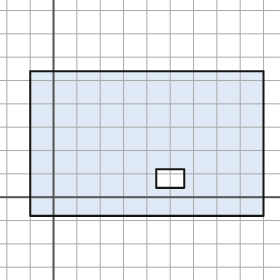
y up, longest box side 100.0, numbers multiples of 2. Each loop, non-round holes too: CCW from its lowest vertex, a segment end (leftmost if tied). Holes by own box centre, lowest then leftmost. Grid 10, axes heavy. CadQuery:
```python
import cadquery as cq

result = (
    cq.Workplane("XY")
    .moveTo(-10.0, -8.0)
    .lineTo(90.0, -8.0)
    .lineTo(90.0, 54.0)
    .lineTo(-10.0, 54.0)
    .close()
    .moveTo(44.0, 4.0)
    .lineTo(56.0, 4.0)
    .lineTo(56.0, 12.0)
    .lineTo(44.0, 12.0)
    .close()
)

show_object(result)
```